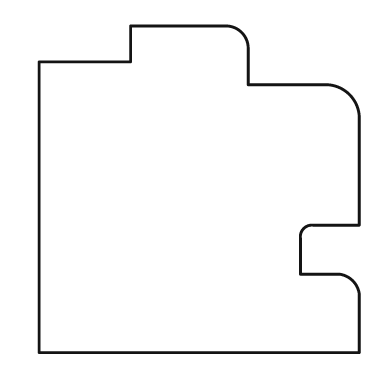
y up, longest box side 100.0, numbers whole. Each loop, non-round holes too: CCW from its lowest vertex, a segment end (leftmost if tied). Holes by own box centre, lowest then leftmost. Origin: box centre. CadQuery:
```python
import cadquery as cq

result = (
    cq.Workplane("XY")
    .moveTo(-49.0, -50.0)
    .lineTo(49.0, -50.0)
    .lineTo(49.0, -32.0)
    .threePointArc((47.0, -28.0), (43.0, -26.0))
    .lineTo(31.0, -26.0)
    .lineTo(31.0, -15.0)
    .threePointArc((32.0, -12.0), (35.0, -11.0))
    .lineTo(49.0, -11.0)
    .lineTo(49.0, 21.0)
    .threePointArc((46.0, 29.0), (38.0, 32.0))
    .lineTo(15.0, 32.0)
    .lineTo(15.0, 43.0)
    .threePointArc((13.0, 48.0), (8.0, 50.0))
    .lineTo(-21.0, 50.0)
    .lineTo(-21.0, 39.0)
    .lineTo(-49.0, 39.0)
    .close()
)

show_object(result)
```